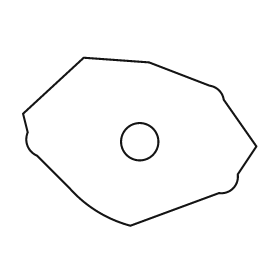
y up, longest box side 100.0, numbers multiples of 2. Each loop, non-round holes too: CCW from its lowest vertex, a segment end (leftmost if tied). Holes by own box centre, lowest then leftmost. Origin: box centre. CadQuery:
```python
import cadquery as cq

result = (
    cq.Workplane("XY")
    .moveTo(-4.0, -36.0)
    .lineTo(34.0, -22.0)
    .threePointArc((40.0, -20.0), (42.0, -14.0))
    .lineTo(50.0, -2.0)
    .lineTo(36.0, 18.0)
    .threePointArc((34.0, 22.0), (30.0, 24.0))
    .lineTo(4.0, 34.0)
    .lineTo(-24.0, 36.0)
    .lineTo(-50.0, 12.0)
    .lineTo(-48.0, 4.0)
    .threePointArc((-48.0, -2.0), (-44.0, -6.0))
    .lineTo(-30.0, -20.0)
    .threePointArc((-18.0, -30.0), (-4.0, -36.0))
    .close()
    .moveTo(0.0, 0.0)
    .circle(8.0)
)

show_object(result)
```